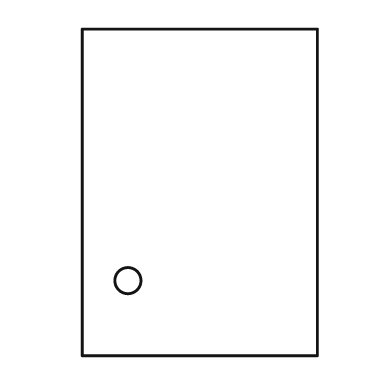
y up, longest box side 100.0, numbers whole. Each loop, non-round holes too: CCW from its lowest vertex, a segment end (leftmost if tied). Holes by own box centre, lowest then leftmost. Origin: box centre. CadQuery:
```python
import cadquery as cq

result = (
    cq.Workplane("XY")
    .moveTo(-36.0, -50.0)
    .lineTo(36.0, -50.0)
    .lineTo(36.0, 50.0)
    .lineTo(-36.0, 50.0)
    .close()
    .moveTo(-22.0, -27.0)
    .circle(4.0)
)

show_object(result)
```